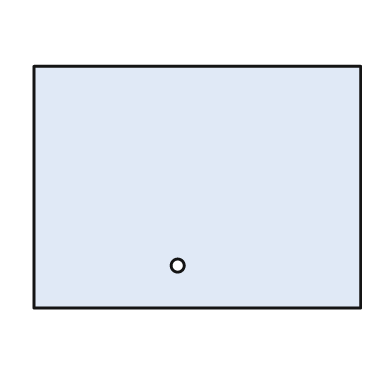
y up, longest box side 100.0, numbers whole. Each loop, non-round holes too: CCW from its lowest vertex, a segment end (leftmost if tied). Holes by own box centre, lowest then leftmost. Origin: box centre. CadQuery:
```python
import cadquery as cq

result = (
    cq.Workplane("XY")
    .moveTo(-50.0, -37.0)
    .lineTo(50.0, -37.0)
    .lineTo(50.0, 37.0)
    .lineTo(-50.0, 37.0)
    .close()
    .moveTo(-6.0, -24.0)
    .circle(2.0)
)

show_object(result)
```